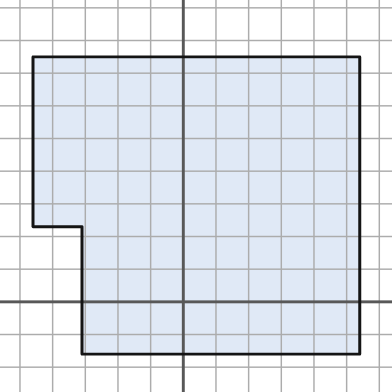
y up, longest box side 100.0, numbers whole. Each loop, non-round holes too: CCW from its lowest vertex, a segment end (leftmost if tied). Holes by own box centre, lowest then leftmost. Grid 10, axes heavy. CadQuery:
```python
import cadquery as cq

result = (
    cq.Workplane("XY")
    .moveTo(-31.0, -16.0)
    .lineTo(54.0, -16.0)
    .lineTo(54.0, 75.0)
    .lineTo(-46.0, 75.0)
    .lineTo(-46.0, 23.0)
    .lineTo(-31.0, 23.0)
    .close()
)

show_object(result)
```